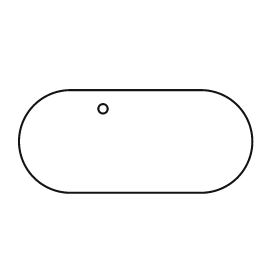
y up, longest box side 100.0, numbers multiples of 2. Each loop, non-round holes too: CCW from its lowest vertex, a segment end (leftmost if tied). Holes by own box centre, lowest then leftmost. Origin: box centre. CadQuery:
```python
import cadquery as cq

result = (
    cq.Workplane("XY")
    .moveTo(-28.0, -22.0)
    .lineTo(28.0, -22.0)
    .threePointArc((50.0, 0.0), (28.0, 22.0))
    .lineTo(-28.0, 22.0)
    .threePointArc((-50.0, 0.0), (-28.0, -22.0))
    .close()
    .moveTo(-14.0, 14.0)
    .circle(2.0)
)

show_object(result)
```